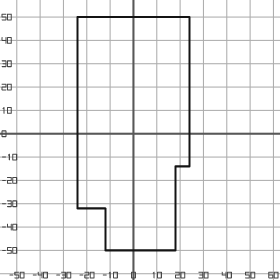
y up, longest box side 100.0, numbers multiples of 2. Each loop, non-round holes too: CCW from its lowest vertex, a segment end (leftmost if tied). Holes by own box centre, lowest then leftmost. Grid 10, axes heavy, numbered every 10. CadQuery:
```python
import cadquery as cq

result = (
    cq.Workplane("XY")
    .moveTo(-12.0, -50.0)
    .lineTo(18.0, -50.0)
    .lineTo(18.0, -14.0)
    .lineTo(24.0, -14.0)
    .lineTo(24.0, 50.0)
    .lineTo(-24.0, 50.0)
    .lineTo(-24.0, -32.0)
    .lineTo(-12.0, -32.0)
    .close()
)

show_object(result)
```